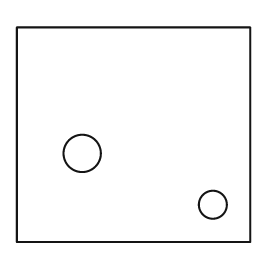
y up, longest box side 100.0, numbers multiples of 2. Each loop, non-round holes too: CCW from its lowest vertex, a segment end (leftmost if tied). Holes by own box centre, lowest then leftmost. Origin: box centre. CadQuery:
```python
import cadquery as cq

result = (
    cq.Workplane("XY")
    .moveTo(-50.0, -46.0)
    .lineTo(50.0, -46.0)
    .lineTo(50.0, 46.0)
    .lineTo(-50.0, 46.0)
    .close()
    .moveTo(34.0, -30.0)
    .circle(6.0)
    .moveTo(-22.0, -8.0)
    .circle(8.0)
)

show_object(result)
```